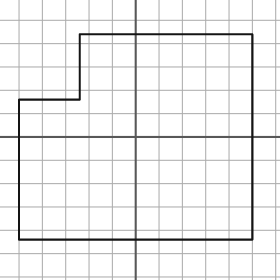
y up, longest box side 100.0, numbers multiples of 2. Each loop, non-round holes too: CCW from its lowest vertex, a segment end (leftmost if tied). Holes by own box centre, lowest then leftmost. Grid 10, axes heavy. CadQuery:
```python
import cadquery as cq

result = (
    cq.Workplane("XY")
    .moveTo(-50.0, -44.0)
    .lineTo(50.0, -44.0)
    .lineTo(50.0, 44.0)
    .lineTo(-24.0, 44.0)
    .lineTo(-24.0, 16.0)
    .lineTo(-50.0, 16.0)
    .close()
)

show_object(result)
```